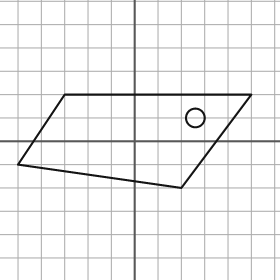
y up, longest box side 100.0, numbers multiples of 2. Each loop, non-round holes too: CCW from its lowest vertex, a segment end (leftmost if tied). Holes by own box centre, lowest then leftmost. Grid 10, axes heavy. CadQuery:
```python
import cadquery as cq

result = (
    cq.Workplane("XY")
    .moveTo(20.0, -20.0)
    .lineTo(50.0, 20.0)
    .lineTo(-30.0, 20.0)
    .lineTo(-50.0, -10.0)
    .close()
    .moveTo(26.0, 10.0)
    .circle(4.0)
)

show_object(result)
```